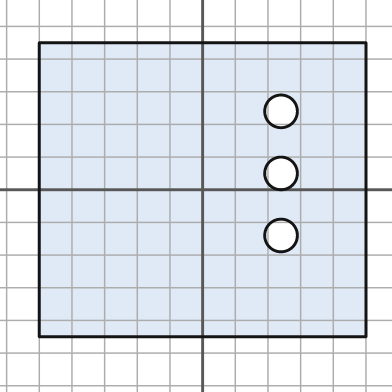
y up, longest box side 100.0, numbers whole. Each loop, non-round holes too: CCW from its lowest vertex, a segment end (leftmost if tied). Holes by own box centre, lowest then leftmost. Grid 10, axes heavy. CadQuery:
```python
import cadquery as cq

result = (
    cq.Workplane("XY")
    .moveTo(-50.0, -45.0)
    .lineTo(50.0, -45.0)
    .lineTo(50.0, 45.0)
    .lineTo(-50.0, 45.0)
    .close()
    .moveTo(24.0, -14.0)
    .circle(5.0)
    .moveTo(24.0, 5.0)
    .circle(5.0)
    .moveTo(24.0, 24.0)
    .circle(5.0)
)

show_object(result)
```